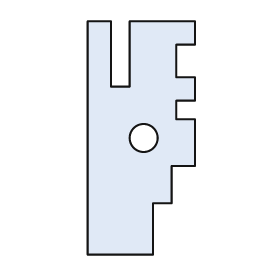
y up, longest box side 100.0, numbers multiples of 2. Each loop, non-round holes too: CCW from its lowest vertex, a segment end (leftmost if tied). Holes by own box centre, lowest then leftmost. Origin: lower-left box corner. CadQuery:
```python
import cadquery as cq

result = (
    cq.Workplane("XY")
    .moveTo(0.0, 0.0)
    .lineTo(28.0, 0.0)
    .lineTo(28.0, 22.0)
    .lineTo(36.0, 22.0)
    .lineTo(36.0, 38.0)
    .lineTo(46.0, 38.0)
    .lineTo(46.0, 58.0)
    .lineTo(38.0, 58.0)
    .lineTo(38.0, 66.0)
    .lineTo(46.0, 66.0)
    .lineTo(46.0, 76.0)
    .lineTo(38.0, 76.0)
    .lineTo(38.0, 90.0)
    .lineTo(46.0, 90.0)
    .lineTo(46.0, 100.0)
    .lineTo(18.0, 100.0)
    .lineTo(18.0, 72.0)
    .lineTo(10.0, 72.0)
    .lineTo(10.0, 100.0)
    .lineTo(0.0, 100.0)
    .close()
    .moveTo(24.0, 50.0)
    .circle(6.0)
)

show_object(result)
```